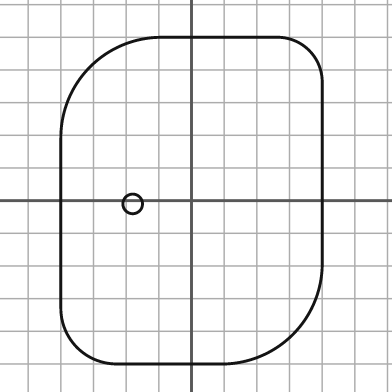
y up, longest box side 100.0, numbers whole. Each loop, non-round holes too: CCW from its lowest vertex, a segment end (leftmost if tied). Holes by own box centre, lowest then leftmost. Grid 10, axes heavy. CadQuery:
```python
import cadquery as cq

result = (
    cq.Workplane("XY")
    .moveTo(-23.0, -50.0)
    .lineTo(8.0, -50.0)
    .threePointArc((31.0, -41.0), (40.0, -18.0))
    .lineTo(40.0, 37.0)
    .threePointArc((36.0, 46.0), (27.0, 50.0))
    .lineTo(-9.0, 50.0)
    .threePointArc((-31.0, 41.0), (-40.0, 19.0))
    .lineTo(-40.0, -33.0)
    .threePointArc((-35.0, -45.0), (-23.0, -50.0))
    .close()
    .moveTo(-18.0, -1.0)
    .circle(3.0)
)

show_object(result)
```